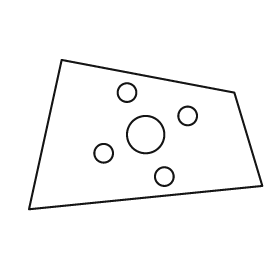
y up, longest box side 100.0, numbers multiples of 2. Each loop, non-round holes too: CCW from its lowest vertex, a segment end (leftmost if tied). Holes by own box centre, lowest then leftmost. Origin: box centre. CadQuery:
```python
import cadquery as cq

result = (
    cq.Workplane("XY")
    .moveTo(-50.0, -32.0)
    .lineTo(50.0, -22.0)
    .lineTo(38.0, 18.0)
    .lineTo(-36.0, 32.0)
    .close()
    .moveTo(8.0, -18.0)
    .circle(4.0)
    .moveTo(-18.0, -8.0)
    .circle(4.0)
    .moveTo(0.0, 0.0)
    .circle(8.0)
    .moveTo(18.0, 8.0)
    .circle(4.0)
    .moveTo(-8.0, 18.0)
    .circle(4.0)
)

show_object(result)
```